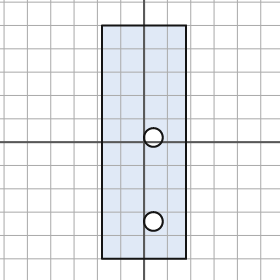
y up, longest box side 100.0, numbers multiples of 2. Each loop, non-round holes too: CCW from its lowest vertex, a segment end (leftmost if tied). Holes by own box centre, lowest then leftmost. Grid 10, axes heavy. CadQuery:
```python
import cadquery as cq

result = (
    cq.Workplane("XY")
    .moveTo(-18.0, -50.0)
    .lineTo(18.0, -50.0)
    .lineTo(18.0, 50.0)
    .lineTo(-18.0, 50.0)
    .close()
    .moveTo(4.0, -34.0)
    .circle(4.0)
    .moveTo(4.0, 2.0)
    .circle(4.0)
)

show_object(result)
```